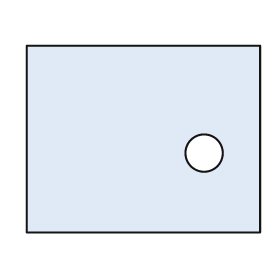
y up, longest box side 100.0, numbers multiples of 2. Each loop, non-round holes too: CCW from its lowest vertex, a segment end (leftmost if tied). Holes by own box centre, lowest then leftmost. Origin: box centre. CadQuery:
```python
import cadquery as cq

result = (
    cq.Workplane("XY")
    .moveTo(-50.0, -40.0)
    .lineTo(50.0, -40.0)
    .lineTo(50.0, 40.0)
    .lineTo(-50.0, 40.0)
    .close()
    .moveTo(26.0, -6.0)
    .circle(8.0)
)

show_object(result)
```